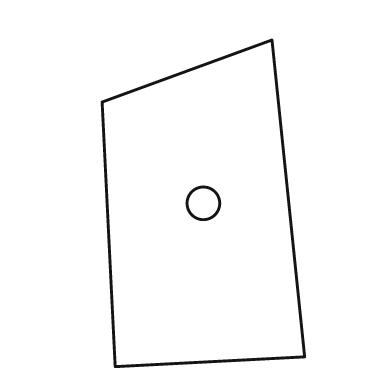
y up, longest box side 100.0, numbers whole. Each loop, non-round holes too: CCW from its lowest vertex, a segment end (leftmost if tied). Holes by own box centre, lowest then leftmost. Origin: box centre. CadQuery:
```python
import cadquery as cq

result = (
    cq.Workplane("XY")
    .moveTo(-27.0, -50.0)
    .lineTo(31.0, -47.0)
    .lineTo(21.0, 50.0)
    .lineTo(-31.0, 31.0)
    .close()
    .moveTo(0.0, 0.0)
    .circle(5.0)
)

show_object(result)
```